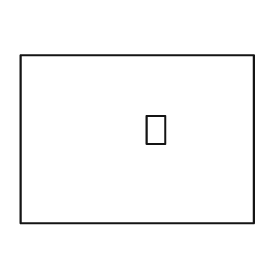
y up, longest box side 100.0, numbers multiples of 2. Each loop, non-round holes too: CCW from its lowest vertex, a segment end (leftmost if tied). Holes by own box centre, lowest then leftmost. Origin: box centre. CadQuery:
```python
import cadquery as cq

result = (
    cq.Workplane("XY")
    .moveTo(-50.0, -36.0)
    .lineTo(50.0, -36.0)
    .lineTo(50.0, 36.0)
    .lineTo(-50.0, 36.0)
    .close()
    .moveTo(4.0, -2.0)
    .lineTo(12.0, -2.0)
    .lineTo(12.0, 10.0)
    .lineTo(4.0, 10.0)
    .close()
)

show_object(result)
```